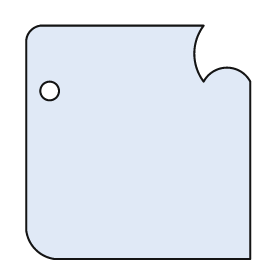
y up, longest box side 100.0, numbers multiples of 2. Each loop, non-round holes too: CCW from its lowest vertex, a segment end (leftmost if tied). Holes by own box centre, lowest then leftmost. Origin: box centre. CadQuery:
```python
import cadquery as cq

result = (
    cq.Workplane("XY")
    .moveTo(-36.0, -50.0)
    .lineTo(48.0, -50.0)
    .lineTo(48.0, 26.0)
    .threePointArc((38.0, 32.0), (28.0, 26.0))
    .threePointArc((24.0, 38.0), (28.0, 50.0))
    .lineTo(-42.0, 50.0)
    .threePointArc((-46.0, 48.0), (-48.0, 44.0))
    .lineTo(-48.0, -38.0)
    .threePointArc((-44.0, -46.0), (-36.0, -50.0))
    .close()
    .moveTo(-38.0, 22.0)
    .circle(4.0)
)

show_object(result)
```